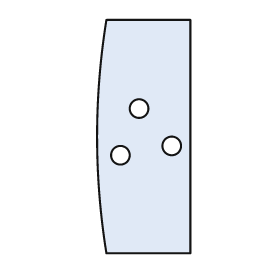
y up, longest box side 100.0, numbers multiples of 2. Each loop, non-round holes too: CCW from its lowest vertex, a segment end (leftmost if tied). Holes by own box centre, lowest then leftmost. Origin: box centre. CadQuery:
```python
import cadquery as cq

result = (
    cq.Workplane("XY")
    .moveTo(-16.0, -50.0)
    .lineTo(20.0, -50.0)
    .lineTo(20.0, 50.0)
    .lineTo(-16.0, 50.0)
    .threePointArc((-20.0, 0.0), (-16.0, -50.0))
    .close()
    .moveTo(-10.0, -8.0)
    .circle(4.0)
    .moveTo(12.0, -4.0)
    .circle(4.0)
    .moveTo(-2.0, 12.0)
    .circle(4.0)
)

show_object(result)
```